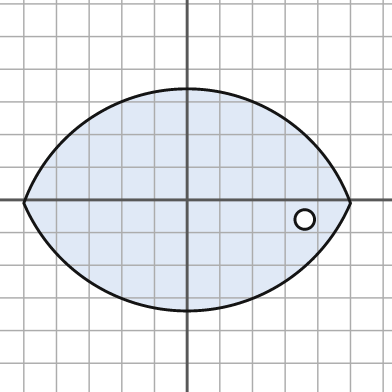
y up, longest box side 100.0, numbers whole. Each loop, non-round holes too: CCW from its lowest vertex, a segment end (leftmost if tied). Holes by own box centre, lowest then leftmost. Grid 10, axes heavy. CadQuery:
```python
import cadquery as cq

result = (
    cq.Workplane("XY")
    .moveTo(-50.0, -1.0)
    .threePointArc((0.0, -34.0), (50.0, -1.0))
    .threePointArc((0.0, 34.0), (-50.0, -1.0))
    .close()
    .moveTo(36.0, -6.0)
    .circle(3.0)
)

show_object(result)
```